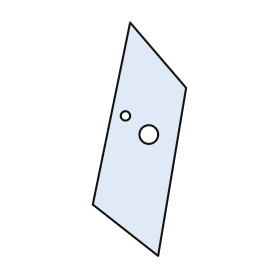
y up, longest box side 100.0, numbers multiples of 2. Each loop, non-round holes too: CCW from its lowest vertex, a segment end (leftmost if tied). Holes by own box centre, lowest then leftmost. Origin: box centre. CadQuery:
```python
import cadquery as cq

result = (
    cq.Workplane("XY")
    .moveTo(8.0, -50.0)
    .lineTo(20.0, 22.0)
    .lineTo(-4.0, 50.0)
    .lineTo(-20.0, -28.0)
    .close()
    .moveTo(4.0, 2.0)
    .circle(4.0)
    .moveTo(-6.0, 10.0)
    .circle(2.0)
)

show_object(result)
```